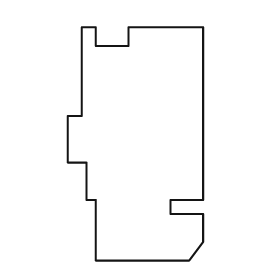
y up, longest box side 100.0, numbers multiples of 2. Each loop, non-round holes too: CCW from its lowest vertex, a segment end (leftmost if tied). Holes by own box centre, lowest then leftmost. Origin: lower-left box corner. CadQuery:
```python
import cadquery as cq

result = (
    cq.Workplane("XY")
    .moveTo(12.0, 0.0)
    .lineTo(52.0, 0.0)
    .lineTo(58.0, 8.0)
    .lineTo(58.0, 20.0)
    .lineTo(44.0, 20.0)
    .lineTo(44.0, 26.0)
    .lineTo(58.0, 26.0)
    .lineTo(58.0, 100.0)
    .lineTo(26.0, 100.0)
    .lineTo(26.0, 92.0)
    .lineTo(12.0, 92.0)
    .lineTo(12.0, 100.0)
    .lineTo(6.0, 100.0)
    .lineTo(6.0, 62.0)
    .lineTo(0.0, 62.0)
    .lineTo(0.0, 42.0)
    .lineTo(8.0, 42.0)
    .lineTo(8.0, 26.0)
    .lineTo(12.0, 26.0)
    .close()
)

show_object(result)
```